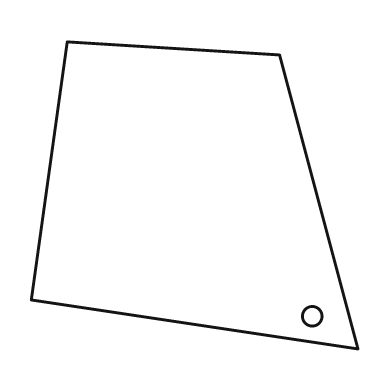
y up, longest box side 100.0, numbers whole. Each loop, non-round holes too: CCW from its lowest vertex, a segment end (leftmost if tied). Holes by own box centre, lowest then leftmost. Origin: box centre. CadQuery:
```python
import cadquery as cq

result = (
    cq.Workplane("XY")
    .moveTo(50.0, -47.0)
    .lineTo(26.0, 43.0)
    .lineTo(-39.0, 47.0)
    .lineTo(-50.0, -32.0)
    .close()
    .moveTo(36.0, -37.0)
    .circle(3.0)
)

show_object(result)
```